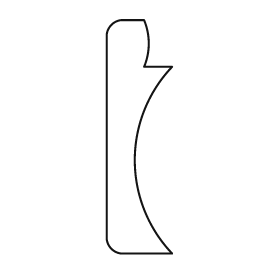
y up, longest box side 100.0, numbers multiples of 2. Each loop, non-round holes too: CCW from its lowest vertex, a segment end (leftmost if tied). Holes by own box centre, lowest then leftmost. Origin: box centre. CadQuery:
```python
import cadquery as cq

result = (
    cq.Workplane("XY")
    .moveTo(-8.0, -50.0)
    .lineTo(14.0, -50.0)
    .threePointArc((-2.0, -10.0), (14.0, 30.0))
    .lineTo(2.0, 30.0)
    .threePointArc((4.0, 40.0), (2.0, 50.0))
    .lineTo(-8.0, 50.0)
    .threePointArc((-12.0, 48.0), (-14.0, 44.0))
    .lineTo(-14.0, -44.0)
    .threePointArc((-12.0, -48.0), (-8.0, -50.0))
    .close()
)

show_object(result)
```